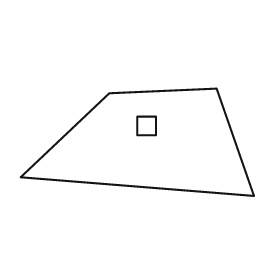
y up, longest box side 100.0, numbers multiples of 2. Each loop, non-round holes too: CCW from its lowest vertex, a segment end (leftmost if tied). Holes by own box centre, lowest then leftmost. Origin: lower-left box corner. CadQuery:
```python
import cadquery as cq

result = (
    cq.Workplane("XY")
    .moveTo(100.0, 0.0)
    .lineTo(84.0, 46.0)
    .lineTo(38.0, 44.0)
    .lineTo(0.0, 8.0)
    .close()
    .moveTo(50.0, 26.0)
    .lineTo(58.0, 26.0)
    .lineTo(58.0, 34.0)
    .lineTo(50.0, 34.0)
    .close()
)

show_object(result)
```